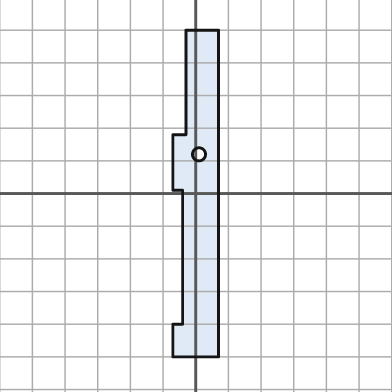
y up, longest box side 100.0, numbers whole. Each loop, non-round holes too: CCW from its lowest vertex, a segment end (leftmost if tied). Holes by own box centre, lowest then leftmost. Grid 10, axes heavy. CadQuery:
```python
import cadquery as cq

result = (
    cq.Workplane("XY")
    .moveTo(-7.0, -50.0)
    .lineTo(7.0, -50.0)
    .lineTo(7.0, 50.0)
    .lineTo(-3.0, 50.0)
    .lineTo(-3.0, 18.0)
    .lineTo(-7.0, 18.0)
    .lineTo(-7.0, 1.0)
    .lineTo(-4.0, 1.0)
    .lineTo(-4.0, -40.0)
    .lineTo(-7.0, -40.0)
    .close()
    .moveTo(1.0, 12.0)
    .circle(2.0)
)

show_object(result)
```